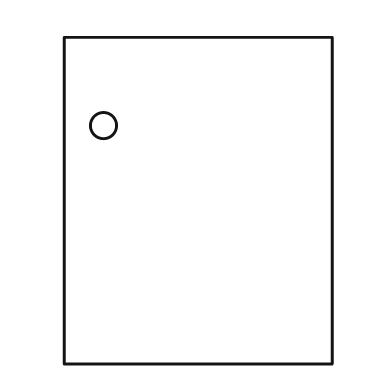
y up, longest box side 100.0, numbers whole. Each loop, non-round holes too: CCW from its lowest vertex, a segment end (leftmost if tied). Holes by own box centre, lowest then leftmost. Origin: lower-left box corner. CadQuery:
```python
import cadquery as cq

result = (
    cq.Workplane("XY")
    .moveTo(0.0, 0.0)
    .lineTo(82.0, 0.0)
    .lineTo(82.0, 100.0)
    .lineTo(0.0, 100.0)
    .close()
    .moveTo(12.0, 73.0)
    .circle(4.0)
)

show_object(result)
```